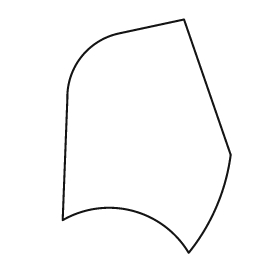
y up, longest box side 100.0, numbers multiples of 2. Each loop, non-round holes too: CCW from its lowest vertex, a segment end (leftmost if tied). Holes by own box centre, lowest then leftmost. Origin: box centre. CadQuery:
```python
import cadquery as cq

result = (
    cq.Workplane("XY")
    .moveTo(18.0, -50.0)
    .threePointArc((30.0, -30.0), (36.0, -8.0))
    .lineTo(16.0, 50.0)
    .lineTo(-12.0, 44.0)
    .threePointArc((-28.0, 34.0), (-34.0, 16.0))
    .lineTo(-36.0, -36.0)
    .threePointArc((-6.0, -32.0), (18.0, -50.0))
    .close()
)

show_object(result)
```